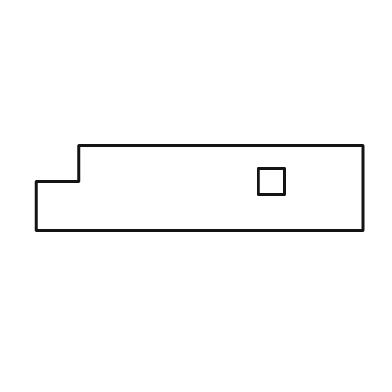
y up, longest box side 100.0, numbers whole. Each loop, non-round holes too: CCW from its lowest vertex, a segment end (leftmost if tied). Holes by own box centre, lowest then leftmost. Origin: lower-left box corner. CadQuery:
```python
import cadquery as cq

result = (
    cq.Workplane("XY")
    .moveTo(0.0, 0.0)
    .lineTo(100.0, 0.0)
    .lineTo(100.0, 26.0)
    .lineTo(13.0, 26.0)
    .lineTo(13.0, 15.0)
    .lineTo(0.0, 15.0)
    .close()
    .moveTo(68.0, 11.0)
    .lineTo(76.0, 11.0)
    .lineTo(76.0, 19.0)
    .lineTo(68.0, 19.0)
    .close()
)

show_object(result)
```